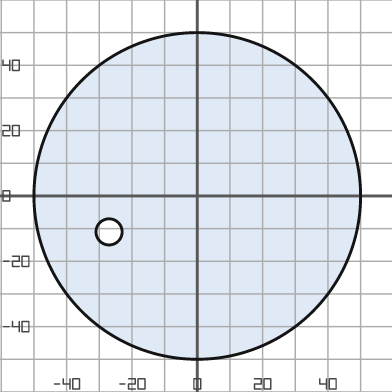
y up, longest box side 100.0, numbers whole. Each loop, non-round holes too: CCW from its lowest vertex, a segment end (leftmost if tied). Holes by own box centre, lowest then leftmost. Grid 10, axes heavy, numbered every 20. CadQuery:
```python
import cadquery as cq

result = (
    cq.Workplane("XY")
    .moveTo(0.0, 0.0)
    .circle(50.0)
    .moveTo(-27.0, -11.0)
    .circle(4.0)
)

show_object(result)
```